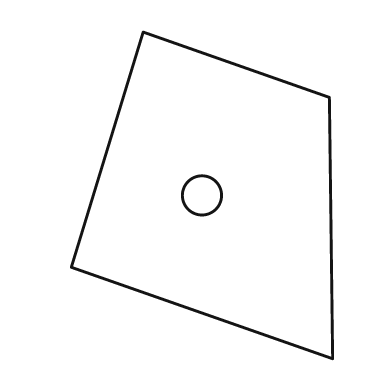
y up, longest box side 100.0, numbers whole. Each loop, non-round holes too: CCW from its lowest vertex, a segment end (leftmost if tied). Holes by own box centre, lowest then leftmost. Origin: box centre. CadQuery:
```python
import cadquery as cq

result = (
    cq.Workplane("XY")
    .moveTo(40.0, -50.0)
    .lineTo(39.0, 30.0)
    .lineTo(-18.0, 50.0)
    .lineTo(-40.0, -22.0)
    .close()
    .moveTo(0.0, 0.0)
    .circle(6.0)
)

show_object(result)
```